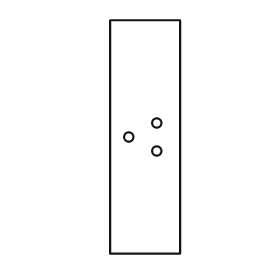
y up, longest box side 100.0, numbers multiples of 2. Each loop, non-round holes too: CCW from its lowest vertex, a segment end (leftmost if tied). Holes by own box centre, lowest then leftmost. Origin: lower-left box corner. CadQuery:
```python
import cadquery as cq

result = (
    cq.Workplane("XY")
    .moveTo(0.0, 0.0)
    .lineTo(30.0, 0.0)
    .lineTo(30.0, 100.0)
    .lineTo(0.0, 100.0)
    .close()
    .moveTo(20.0, 44.0)
    .circle(2.0)
    .moveTo(8.0, 50.0)
    .circle(2.0)
    .moveTo(20.0, 56.0)
    .circle(2.0)
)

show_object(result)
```